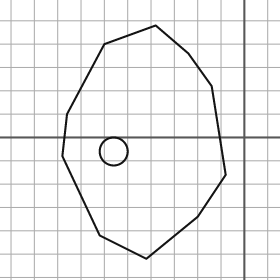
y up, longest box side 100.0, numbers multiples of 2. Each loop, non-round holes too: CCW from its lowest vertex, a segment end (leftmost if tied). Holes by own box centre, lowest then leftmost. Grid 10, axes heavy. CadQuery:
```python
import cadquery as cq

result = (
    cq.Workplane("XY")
    .moveTo(-42.0, -52.0)
    .lineTo(-20.0, -34.0)
    .lineTo(-8.0, -16.0)
    .lineTo(-14.0, 22.0)
    .lineTo(-24.0, 36.0)
    .lineTo(-38.0, 48.0)
    .lineTo(-60.0, 40.0)
    .lineTo(-76.0, 10.0)
    .lineTo(-78.0, -8.0)
    .lineTo(-62.0, -42.0)
    .close()
    .moveTo(-56.0, -6.0)
    .circle(6.0)
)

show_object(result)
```